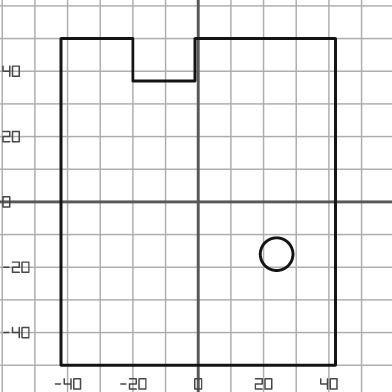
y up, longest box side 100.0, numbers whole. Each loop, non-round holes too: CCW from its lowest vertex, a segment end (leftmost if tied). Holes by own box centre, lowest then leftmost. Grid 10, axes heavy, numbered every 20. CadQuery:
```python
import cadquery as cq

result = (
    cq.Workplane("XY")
    .moveTo(-42.0, -50.0)
    .lineTo(42.0, -50.0)
    .lineTo(42.0, 50.0)
    .lineTo(-1.0, 50.0)
    .lineTo(-1.0, 37.0)
    .lineTo(-20.0, 37.0)
    .lineTo(-20.0, 50.0)
    .lineTo(-42.0, 50.0)
    .close()
    .moveTo(24.0, -16.0)
    .circle(5.0)
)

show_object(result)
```